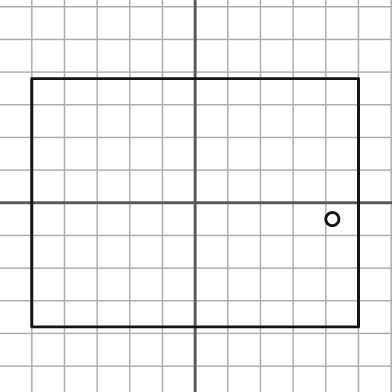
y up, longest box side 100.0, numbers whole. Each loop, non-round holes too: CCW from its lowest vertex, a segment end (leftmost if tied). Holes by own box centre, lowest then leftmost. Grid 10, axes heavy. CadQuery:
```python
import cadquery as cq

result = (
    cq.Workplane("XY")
    .moveTo(-50.0, -38.0)
    .lineTo(50.0, -38.0)
    .lineTo(50.0, 38.0)
    .lineTo(-50.0, 38.0)
    .close()
    .moveTo(42.0, -5.0)
    .circle(2.0)
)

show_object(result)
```